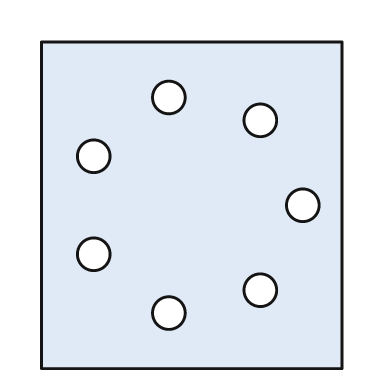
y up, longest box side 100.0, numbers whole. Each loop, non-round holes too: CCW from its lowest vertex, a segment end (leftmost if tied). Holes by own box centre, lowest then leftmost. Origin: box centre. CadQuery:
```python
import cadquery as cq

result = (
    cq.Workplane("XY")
    .moveTo(-46.0, -50.0)
    .lineTo(46.0, -50.0)
    .lineTo(46.0, 50.0)
    .lineTo(-46.0, 50.0)
    .close()
    .moveTo(-7.0, -33.0)
    .circle(5.0)
    .moveTo(21.0, -26.0)
    .circle(5.0)
    .moveTo(-30.0, -15.0)
    .circle(5.0)
    .moveTo(34.0, 0.0)
    .circle(5.0)
    .moveTo(-30.0, 15.0)
    .circle(5.0)
    .moveTo(21.0, 26.0)
    .circle(5.0)
    .moveTo(-7.0, 33.0)
    .circle(5.0)
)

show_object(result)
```